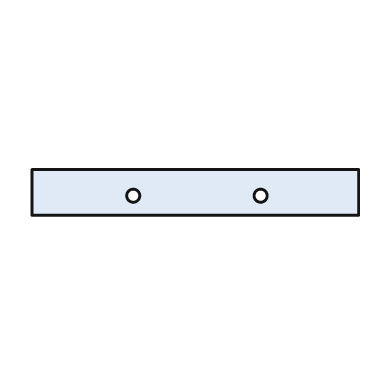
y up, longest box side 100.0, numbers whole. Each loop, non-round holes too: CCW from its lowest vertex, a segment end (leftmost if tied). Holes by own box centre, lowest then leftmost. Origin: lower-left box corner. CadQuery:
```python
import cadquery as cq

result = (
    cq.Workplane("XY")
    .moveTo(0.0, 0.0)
    .lineTo(100.0, 0.0)
    .lineTo(100.0, 14.0)
    .lineTo(0.0, 14.0)
    .close()
    .moveTo(31.0, 6.0)
    .circle(2.0)
    .moveTo(70.0, 6.0)
    .circle(2.0)
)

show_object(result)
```